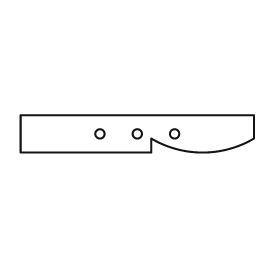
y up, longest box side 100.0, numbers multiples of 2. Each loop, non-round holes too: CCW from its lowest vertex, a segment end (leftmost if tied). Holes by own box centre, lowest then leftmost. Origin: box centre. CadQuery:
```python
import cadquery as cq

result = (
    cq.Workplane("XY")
    .moveTo(-50.0, -8.0)
    .lineTo(6.0, -8.0)
    .lineTo(6.0, -2.0)
    .threePointArc((28.0, -8.0), (50.0, -2.0))
    .lineTo(50.0, 8.0)
    .lineTo(-50.0, 8.0)
    .close()
    .moveTo(-16.0, 0.0)
    .circle(2.0)
    .moveTo(0.0, 0.0)
    .circle(2.0)
    .moveTo(16.0, 0.0)
    .circle(2.0)
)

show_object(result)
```